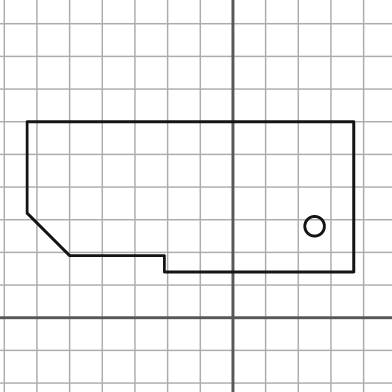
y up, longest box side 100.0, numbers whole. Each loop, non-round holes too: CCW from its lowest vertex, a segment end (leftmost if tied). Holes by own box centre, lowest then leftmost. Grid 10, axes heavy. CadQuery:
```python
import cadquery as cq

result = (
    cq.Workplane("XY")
    .moveTo(-21.0, 14.0)
    .lineTo(37.0, 14.0)
    .lineTo(37.0, 60.0)
    .lineTo(-63.0, 60.0)
    .lineTo(-63.0, 32.0)
    .lineTo(-50.0, 19.0)
    .lineTo(-21.0, 19.0)
    .close()
    .moveTo(25.0, 28.0)
    .circle(3.0)
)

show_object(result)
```